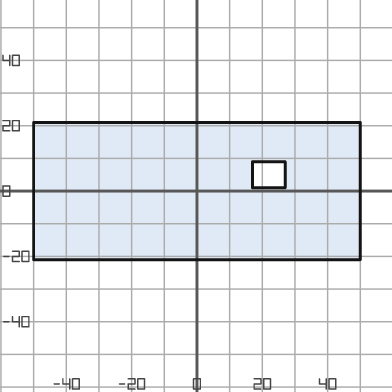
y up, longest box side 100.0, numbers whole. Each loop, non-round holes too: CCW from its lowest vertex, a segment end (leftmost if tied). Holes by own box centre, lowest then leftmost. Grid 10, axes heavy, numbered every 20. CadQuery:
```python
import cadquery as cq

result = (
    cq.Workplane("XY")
    .moveTo(-50.0, -21.0)
    .lineTo(50.0, -21.0)
    .lineTo(50.0, 21.0)
    .lineTo(-50.0, 21.0)
    .close()
    .moveTo(17.0, 1.0)
    .lineTo(27.0, 1.0)
    .lineTo(27.0, 9.0)
    .lineTo(17.0, 9.0)
    .close()
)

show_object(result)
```